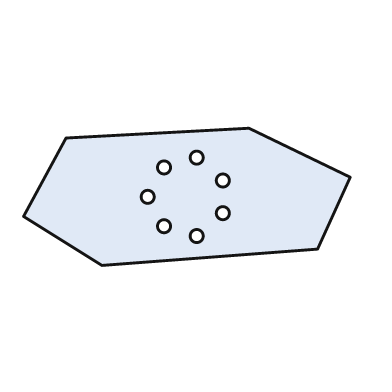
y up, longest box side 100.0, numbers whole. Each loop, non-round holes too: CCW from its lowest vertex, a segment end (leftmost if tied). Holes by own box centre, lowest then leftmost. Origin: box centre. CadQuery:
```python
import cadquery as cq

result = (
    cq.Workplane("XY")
    .moveTo(-26.0, -21.0)
    .lineTo(40.0, -16.0)
    .lineTo(50.0, 6.0)
    .lineTo(19.0, 21.0)
    .lineTo(-37.0, 18.0)
    .lineTo(-50.0, -6.0)
    .close()
    .moveTo(3.0, -12.0)
    .circle(2.0)
    .moveTo(-7.0, -9.0)
    .circle(2.0)
    .moveTo(11.0, -5.0)
    .circle(2.0)
    .moveTo(-12.0, 0.0)
    .circle(2.0)
    .moveTo(11.0, 5.0)
    .circle(2.0)
    .moveTo(-7.0, 9.0)
    .circle(2.0)
    .moveTo(3.0, 12.0)
    .circle(2.0)
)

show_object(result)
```